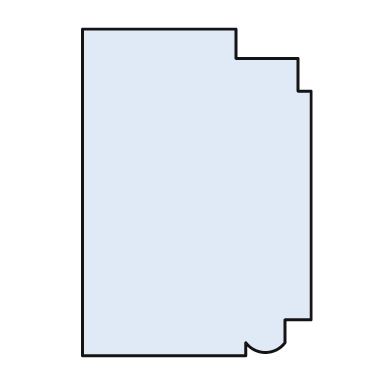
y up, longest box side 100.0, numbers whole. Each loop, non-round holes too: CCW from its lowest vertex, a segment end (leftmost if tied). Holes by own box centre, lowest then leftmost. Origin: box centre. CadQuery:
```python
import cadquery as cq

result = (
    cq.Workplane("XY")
    .moveTo(-35.0, -50.0)
    .lineTo(15.0, -50.0)
    .lineTo(15.0, -46.0)
    .threePointArc((21.0, -49.0), (27.0, -46.0))
    .lineTo(27.0, -39.0)
    .lineTo(35.0, -39.0)
    .lineTo(35.0, 31.0)
    .lineTo(31.0, 31.0)
    .lineTo(31.0, 41.0)
    .lineTo(12.0, 41.0)
    .lineTo(12.0, 50.0)
    .lineTo(-35.0, 50.0)
    .close()
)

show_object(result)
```